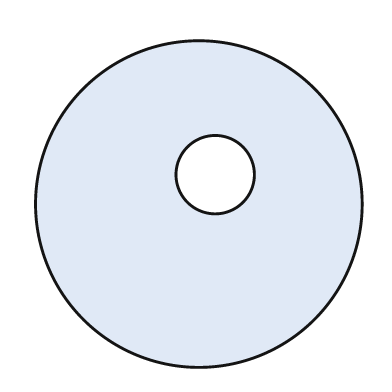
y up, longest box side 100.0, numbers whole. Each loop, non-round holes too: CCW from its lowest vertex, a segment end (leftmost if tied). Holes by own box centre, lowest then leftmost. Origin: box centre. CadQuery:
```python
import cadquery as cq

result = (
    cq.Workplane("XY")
    .moveTo(0.0, 0.0)
    .circle(50.0)
    .moveTo(5.0, 9.0)
    .circle(12.0)
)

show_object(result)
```